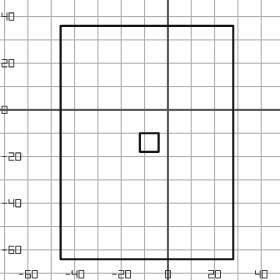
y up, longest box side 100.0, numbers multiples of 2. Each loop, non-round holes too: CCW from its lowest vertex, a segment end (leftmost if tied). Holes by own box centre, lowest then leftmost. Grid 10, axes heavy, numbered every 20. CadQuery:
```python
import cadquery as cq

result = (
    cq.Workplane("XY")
    .moveTo(-46.0, -64.0)
    .lineTo(28.0, -64.0)
    .lineTo(28.0, 36.0)
    .lineTo(-46.0, 36.0)
    .close()
    .moveTo(-12.0, -18.0)
    .lineTo(-4.0, -18.0)
    .lineTo(-4.0, -10.0)
    .lineTo(-12.0, -10.0)
    .close()
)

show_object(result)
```